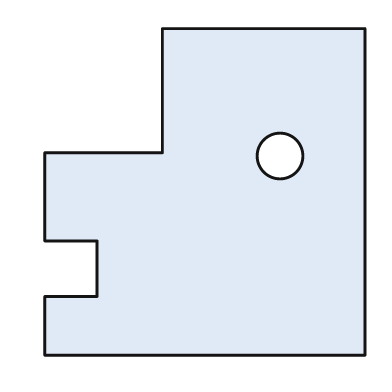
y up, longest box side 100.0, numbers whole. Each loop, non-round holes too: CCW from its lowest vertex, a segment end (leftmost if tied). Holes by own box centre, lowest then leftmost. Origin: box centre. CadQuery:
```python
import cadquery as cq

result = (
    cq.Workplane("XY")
    .moveTo(-49.0, -50.0)
    .lineTo(49.0, -50.0)
    .lineTo(49.0, 50.0)
    .lineTo(-13.0, 50.0)
    .lineTo(-13.0, 12.0)
    .lineTo(-49.0, 12.0)
    .lineTo(-49.0, -15.0)
    .lineTo(-33.0, -15.0)
    .lineTo(-33.0, -32.0)
    .lineTo(-49.0, -32.0)
    .close()
    .moveTo(23.0, 11.0)
    .circle(7.0)
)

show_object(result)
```